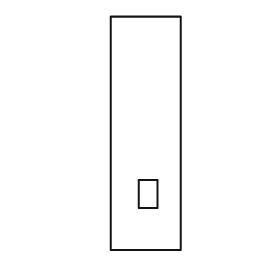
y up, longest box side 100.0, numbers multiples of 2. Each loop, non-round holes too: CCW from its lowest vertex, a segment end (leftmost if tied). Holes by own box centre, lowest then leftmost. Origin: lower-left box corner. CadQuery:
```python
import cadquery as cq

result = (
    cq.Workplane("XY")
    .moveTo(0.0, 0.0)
    .lineTo(30.0, 0.0)
    .lineTo(30.0, 100.0)
    .lineTo(0.0, 100.0)
    .close()
    .moveTo(12.0, 18.0)
    .lineTo(20.0, 18.0)
    .lineTo(20.0, 30.0)
    .lineTo(12.0, 30.0)
    .close()
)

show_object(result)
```